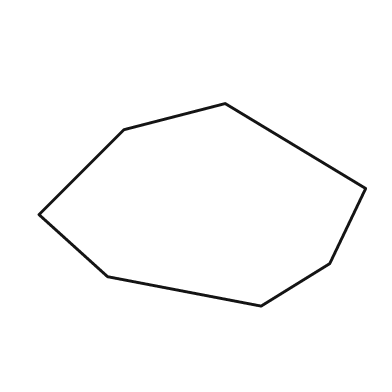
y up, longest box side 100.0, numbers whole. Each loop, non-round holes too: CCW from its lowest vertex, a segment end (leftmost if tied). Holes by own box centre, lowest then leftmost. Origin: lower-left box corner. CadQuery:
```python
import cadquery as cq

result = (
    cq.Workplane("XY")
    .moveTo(68.0, 0.0)
    .lineTo(89.0, 13.0)
    .lineTo(100.0, 36.0)
    .lineTo(57.0, 62.0)
    .lineTo(26.0, 54.0)
    .lineTo(0.0, 28.0)
    .lineTo(21.0, 9.0)
    .close()
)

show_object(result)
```